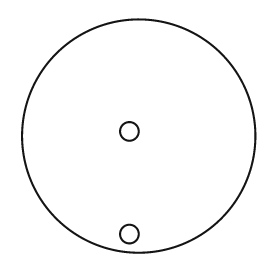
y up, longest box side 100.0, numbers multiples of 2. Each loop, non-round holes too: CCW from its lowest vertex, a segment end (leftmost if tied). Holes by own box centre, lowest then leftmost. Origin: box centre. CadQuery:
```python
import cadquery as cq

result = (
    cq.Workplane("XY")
    .moveTo(0.0, 0.0)
    .circle(50.0)
    .moveTo(-4.0, -42.0)
    .circle(4.0)
    .moveTo(-4.0, 2.0)
    .circle(4.0)
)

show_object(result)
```